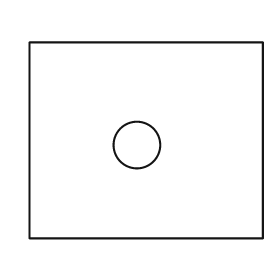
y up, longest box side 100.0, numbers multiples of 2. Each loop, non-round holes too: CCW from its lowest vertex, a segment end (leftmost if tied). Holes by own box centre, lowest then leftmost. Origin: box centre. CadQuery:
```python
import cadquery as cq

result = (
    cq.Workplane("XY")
    .moveTo(-50.0, -42.0)
    .lineTo(50.0, -42.0)
    .lineTo(50.0, 42.0)
    .lineTo(-50.0, 42.0)
    .close()
    .moveTo(-4.0, -2.0)
    .circle(10.0)
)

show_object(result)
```